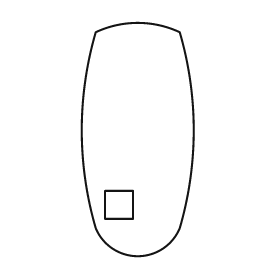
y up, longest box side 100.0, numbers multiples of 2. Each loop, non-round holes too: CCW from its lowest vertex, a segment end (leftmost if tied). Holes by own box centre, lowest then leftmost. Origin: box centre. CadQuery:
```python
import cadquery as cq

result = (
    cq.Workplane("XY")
    .moveTo(-18.0, -38.0)
    .threePointArc((0.0, -50.0), (18.0, -38.0))
    .threePointArc((24.0, 4.0), (18.0, 46.0))
    .threePointArc((0.0, 50.0), (-18.0, 46.0))
    .threePointArc((-24.0, 4.0), (-18.0, -38.0))
    .close()
    .moveTo(-14.0, -34.0)
    .lineTo(-2.0, -34.0)
    .lineTo(-2.0, -22.0)
    .lineTo(-14.0, -22.0)
    .close()
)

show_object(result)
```